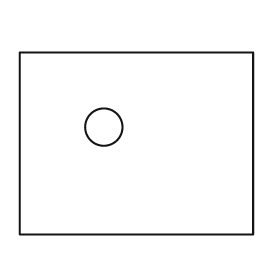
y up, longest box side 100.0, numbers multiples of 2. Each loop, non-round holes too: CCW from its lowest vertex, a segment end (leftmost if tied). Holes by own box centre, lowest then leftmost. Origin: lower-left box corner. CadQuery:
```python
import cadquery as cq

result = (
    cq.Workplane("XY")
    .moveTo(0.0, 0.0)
    .lineTo(100.0, 0.0)
    .lineTo(100.0, 78.0)
    .lineTo(0.0, 78.0)
    .close()
    .moveTo(36.0, 46.0)
    .circle(8.0)
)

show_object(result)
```